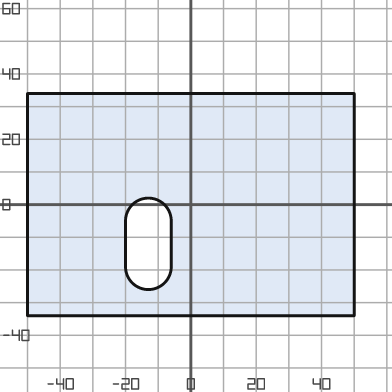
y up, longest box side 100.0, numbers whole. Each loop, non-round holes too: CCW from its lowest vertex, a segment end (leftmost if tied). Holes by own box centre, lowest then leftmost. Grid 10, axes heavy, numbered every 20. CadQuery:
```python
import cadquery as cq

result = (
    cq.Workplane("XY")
    .moveTo(-50.0, -34.0)
    .lineTo(50.0, -34.0)
    .lineTo(50.0, 34.0)
    .lineTo(-50.0, 34.0)
    .close()
    .moveTo(-20.0, -19.0)
    .threePointArc((-13.0, -26.0), (-6.0, -19.0))
    .lineTo(-6.0, -5.0)
    .threePointArc((-13.0, 2.0), (-20.0, -5.0))
    .close()
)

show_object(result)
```